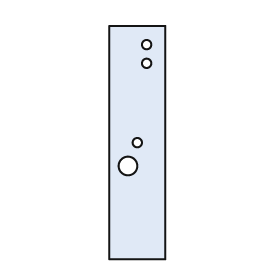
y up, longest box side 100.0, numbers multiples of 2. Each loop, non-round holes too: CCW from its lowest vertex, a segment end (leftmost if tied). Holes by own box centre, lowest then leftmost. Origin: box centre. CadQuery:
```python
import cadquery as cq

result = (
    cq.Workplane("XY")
    .moveTo(-12.0, -50.0)
    .lineTo(12.0, -50.0)
    .lineTo(12.0, 50.0)
    .lineTo(-12.0, 50.0)
    .close()
    .moveTo(-4.0, -10.0)
    .circle(4.0)
    .moveTo(0.0, 0.0)
    .circle(2.0)
    .moveTo(4.0, 34.0)
    .circle(2.0)
    .moveTo(4.0, 42.0)
    .circle(2.0)
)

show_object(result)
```